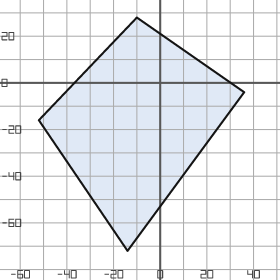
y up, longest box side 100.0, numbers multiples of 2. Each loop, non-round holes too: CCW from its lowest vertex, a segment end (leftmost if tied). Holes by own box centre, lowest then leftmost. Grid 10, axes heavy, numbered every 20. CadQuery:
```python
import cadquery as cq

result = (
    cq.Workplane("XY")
    .moveTo(-14.0, -72.0)
    .lineTo(36.0, -4.0)
    .lineTo(-10.0, 28.0)
    .lineTo(-52.0, -16.0)
    .close()
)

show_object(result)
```